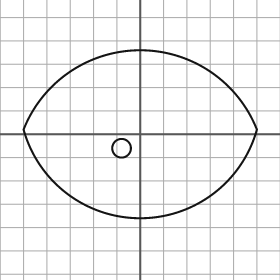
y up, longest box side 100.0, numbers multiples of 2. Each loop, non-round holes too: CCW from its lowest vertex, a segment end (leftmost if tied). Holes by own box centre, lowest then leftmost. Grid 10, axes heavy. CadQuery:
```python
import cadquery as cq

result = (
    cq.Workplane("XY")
    .moveTo(-50.0, 2.0)
    .threePointArc((0.0, -36.0), (50.0, 2.0))
    .threePointArc((0.0, 36.0), (-50.0, 2.0))
    .close()
    .moveTo(-8.0, -6.0)
    .circle(4.0)
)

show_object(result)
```